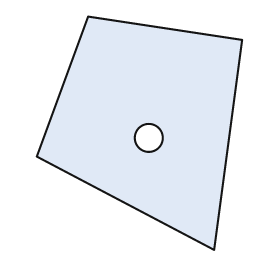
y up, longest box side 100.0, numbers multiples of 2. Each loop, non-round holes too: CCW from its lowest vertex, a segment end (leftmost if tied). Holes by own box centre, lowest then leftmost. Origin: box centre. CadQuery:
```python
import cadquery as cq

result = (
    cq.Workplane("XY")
    .moveTo(32.0, -50.0)
    .lineTo(44.0, 40.0)
    .lineTo(-22.0, 50.0)
    .lineTo(-44.0, -10.0)
    .close()
    .moveTo(4.0, -2.0)
    .circle(6.0)
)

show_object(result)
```